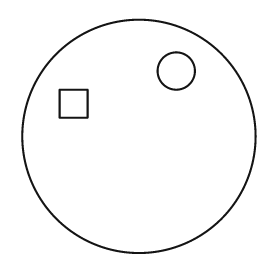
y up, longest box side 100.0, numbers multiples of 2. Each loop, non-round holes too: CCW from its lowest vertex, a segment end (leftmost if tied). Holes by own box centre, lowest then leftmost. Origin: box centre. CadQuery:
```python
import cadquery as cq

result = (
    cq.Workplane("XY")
    .moveTo(0.0, 0.0)
    .circle(50.0)
    .moveTo(-34.0, 8.0)
    .lineTo(-22.0, 8.0)
    .lineTo(-22.0, 20.0)
    .lineTo(-34.0, 20.0)
    .close()
    .moveTo(16.0, 28.0)
    .circle(8.0)
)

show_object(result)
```